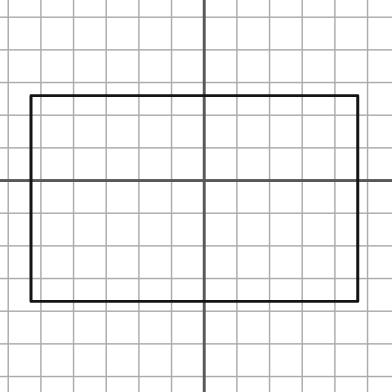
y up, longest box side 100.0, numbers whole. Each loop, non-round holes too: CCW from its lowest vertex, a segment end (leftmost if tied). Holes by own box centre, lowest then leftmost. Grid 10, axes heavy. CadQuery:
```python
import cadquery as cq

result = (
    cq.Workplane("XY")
    .moveTo(-53.0, -37.0)
    .lineTo(47.0, -37.0)
    .lineTo(47.0, 26.0)
    .lineTo(-53.0, 26.0)
    .close()
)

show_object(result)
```